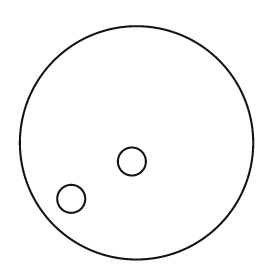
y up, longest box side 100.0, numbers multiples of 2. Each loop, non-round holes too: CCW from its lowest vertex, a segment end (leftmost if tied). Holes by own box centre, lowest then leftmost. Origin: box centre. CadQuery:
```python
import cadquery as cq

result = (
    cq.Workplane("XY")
    .moveTo(0.0, 0.0)
    .circle(50.0)
    .moveTo(-28.0, -24.0)
    .circle(6.0)
    .moveTo(-2.0, -8.0)
    .circle(6.0)
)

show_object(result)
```